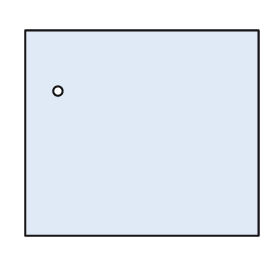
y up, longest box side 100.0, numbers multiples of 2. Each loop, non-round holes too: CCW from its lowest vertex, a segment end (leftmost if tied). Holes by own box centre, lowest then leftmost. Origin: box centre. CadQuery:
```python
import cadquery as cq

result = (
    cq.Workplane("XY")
    .moveTo(-50.0, -44.0)
    .lineTo(50.0, -44.0)
    .lineTo(50.0, 44.0)
    .lineTo(-50.0, 44.0)
    .close()
    .moveTo(-36.0, 18.0)
    .circle(2.0)
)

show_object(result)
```